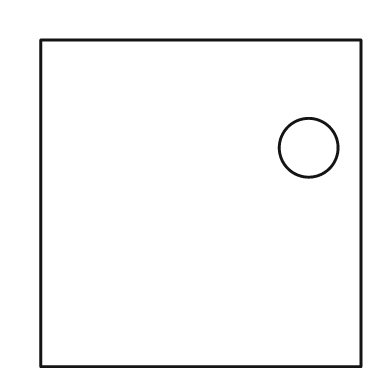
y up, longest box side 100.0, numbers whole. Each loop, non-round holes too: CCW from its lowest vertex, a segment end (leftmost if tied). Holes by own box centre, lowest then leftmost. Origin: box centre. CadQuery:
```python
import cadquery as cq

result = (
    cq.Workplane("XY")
    .moveTo(-49.0, -50.0)
    .lineTo(49.0, -50.0)
    .lineTo(49.0, 50.0)
    .lineTo(-49.0, 50.0)
    .close()
    .moveTo(33.0, 17.0)
    .circle(9.0)
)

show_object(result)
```